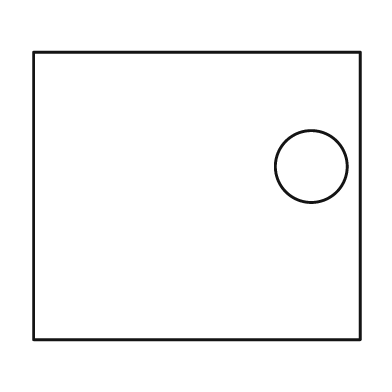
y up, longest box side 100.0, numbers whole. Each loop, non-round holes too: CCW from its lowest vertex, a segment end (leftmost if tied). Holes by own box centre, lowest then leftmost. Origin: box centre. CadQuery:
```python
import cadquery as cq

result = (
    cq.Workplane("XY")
    .moveTo(-50.0, -44.0)
    .lineTo(50.0, -44.0)
    .lineTo(50.0, 44.0)
    .lineTo(-50.0, 44.0)
    .close()
    .moveTo(35.0, 9.0)
    .circle(11.0)
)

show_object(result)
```